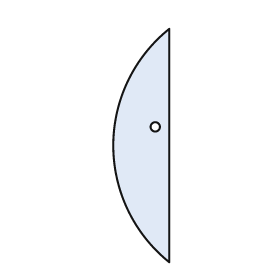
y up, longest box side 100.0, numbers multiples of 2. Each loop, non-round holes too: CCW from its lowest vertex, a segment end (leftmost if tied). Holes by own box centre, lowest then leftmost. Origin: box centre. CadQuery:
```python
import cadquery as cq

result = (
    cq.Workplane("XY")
    .moveTo(12.0, -50.0)
    .lineTo(12.0, 50.0)
    .threePointArc((-12.0, 0.0), (12.0, -50.0))
    .close()
    .moveTo(6.0, 8.0)
    .circle(2.0)
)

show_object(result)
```